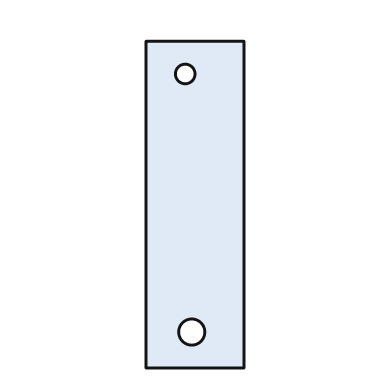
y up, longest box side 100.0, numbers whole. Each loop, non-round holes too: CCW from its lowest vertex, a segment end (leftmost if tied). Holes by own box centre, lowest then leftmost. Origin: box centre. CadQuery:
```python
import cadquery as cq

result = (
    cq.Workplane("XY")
    .moveTo(-15.0, -50.0)
    .lineTo(15.0, -50.0)
    .lineTo(15.0, 50.0)
    .lineTo(-15.0, 50.0)
    .close()
    .moveTo(-1.0, -39.0)
    .circle(4.0)
    .moveTo(-3.0, 40.0)
    .circle(3.0)
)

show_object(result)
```